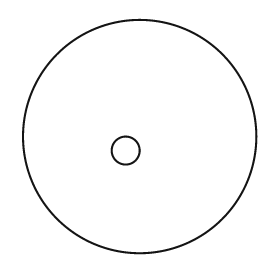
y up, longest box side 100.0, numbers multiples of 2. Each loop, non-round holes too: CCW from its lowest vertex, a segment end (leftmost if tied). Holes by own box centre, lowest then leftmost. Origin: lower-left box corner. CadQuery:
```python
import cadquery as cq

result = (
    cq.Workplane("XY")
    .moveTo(50.0, 50.0)
    .circle(50.0)
    .moveTo(44.0, 44.0)
    .circle(6.0)
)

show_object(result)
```